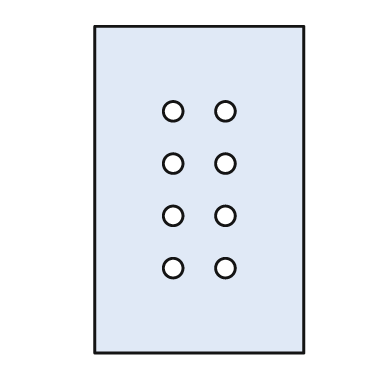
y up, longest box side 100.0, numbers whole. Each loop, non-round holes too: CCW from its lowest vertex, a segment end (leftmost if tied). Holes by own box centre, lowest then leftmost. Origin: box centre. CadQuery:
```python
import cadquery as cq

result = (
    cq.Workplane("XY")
    .moveTo(-32.0, -50.0)
    .lineTo(32.0, -50.0)
    .lineTo(32.0, 50.0)
    .lineTo(-32.0, 50.0)
    .close()
    .moveTo(-8.0, -24.0)
    .circle(3.0)
    .moveTo(8.0, -24.0)
    .circle(3.0)
    .moveTo(-8.0, -8.0)
    .circle(3.0)
    .moveTo(8.0, -8.0)
    .circle(3.0)
    .moveTo(-8.0, 8.0)
    .circle(3.0)
    .moveTo(8.0, 8.0)
    .circle(3.0)
    .moveTo(-8.0, 24.0)
    .circle(3.0)
    .moveTo(8.0, 24.0)
    .circle(3.0)
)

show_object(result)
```